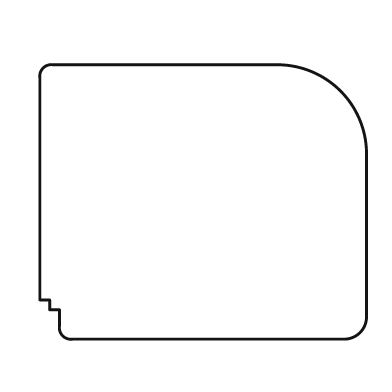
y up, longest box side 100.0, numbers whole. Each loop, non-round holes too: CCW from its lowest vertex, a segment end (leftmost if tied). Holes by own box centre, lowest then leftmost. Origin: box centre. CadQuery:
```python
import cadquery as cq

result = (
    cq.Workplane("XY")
    .moveTo(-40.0, -42.0)
    .lineTo(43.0, -42.0)
    .threePointArc((48.0, -40.0), (50.0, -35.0))
    .lineTo(50.0, 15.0)
    .threePointArc((42.0, 34.0), (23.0, 42.0))
    .lineTo(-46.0, 42.0)
    .threePointArc((-49.0, 41.0), (-50.0, 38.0))
    .lineTo(-50.0, -30.0)
    .lineTo(-47.0, -30.0)
    .lineTo(-47.0, -33.0)
    .lineTo(-44.0, -33.0)
    .lineTo(-44.0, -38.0)
    .threePointArc((-43.0, -41.0), (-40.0, -42.0))
    .close()
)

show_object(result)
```